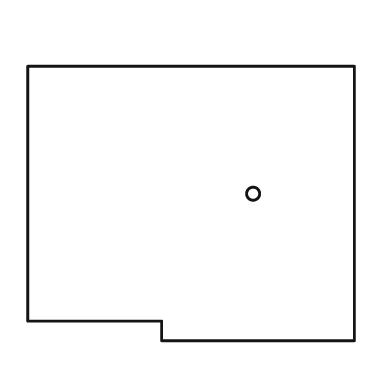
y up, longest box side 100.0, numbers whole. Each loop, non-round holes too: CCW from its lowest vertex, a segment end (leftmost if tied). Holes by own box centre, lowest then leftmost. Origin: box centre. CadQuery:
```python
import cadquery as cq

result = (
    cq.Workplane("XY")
    .moveTo(-9.0, -42.0)
    .lineTo(50.0, -42.0)
    .lineTo(50.0, 42.0)
    .lineTo(-50.0, 42.0)
    .lineTo(-50.0, -36.0)
    .lineTo(-9.0, -36.0)
    .close()
    .moveTo(19.0, 3.0)
    .circle(2.0)
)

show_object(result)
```